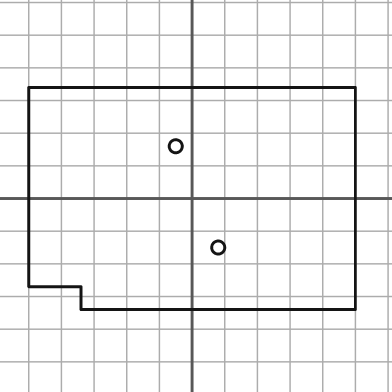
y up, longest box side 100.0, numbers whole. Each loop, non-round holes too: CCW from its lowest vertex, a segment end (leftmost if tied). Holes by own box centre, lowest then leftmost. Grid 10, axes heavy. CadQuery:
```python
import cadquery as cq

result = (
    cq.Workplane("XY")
    .moveTo(-34.0, -34.0)
    .lineTo(50.0, -34.0)
    .lineTo(50.0, 34.0)
    .lineTo(-50.0, 34.0)
    .lineTo(-50.0, -27.0)
    .lineTo(-34.0, -27.0)
    .close()
    .moveTo(8.0, -15.0)
    .circle(2.0)
    .moveTo(-5.0, 16.0)
    .circle(2.0)
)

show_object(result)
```